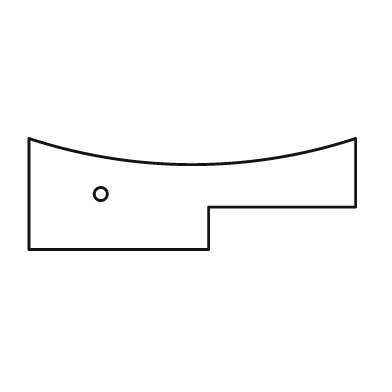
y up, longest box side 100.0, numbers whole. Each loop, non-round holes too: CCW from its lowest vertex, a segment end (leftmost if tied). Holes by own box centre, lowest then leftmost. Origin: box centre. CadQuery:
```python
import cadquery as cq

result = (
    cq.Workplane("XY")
    .moveTo(-50.0, -17.0)
    .lineTo(5.0, -17.0)
    .lineTo(5.0, -4.0)
    .lineTo(50.0, -4.0)
    .lineTo(50.0, 17.0)
    .threePointArc((0.0, 9.0), (-50.0, 17.0))
    .close()
    .moveTo(-28.0, 0.0)
    .circle(2.0)
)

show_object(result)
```